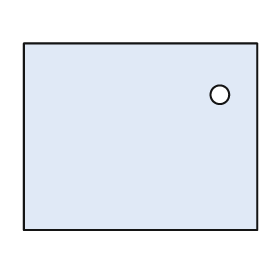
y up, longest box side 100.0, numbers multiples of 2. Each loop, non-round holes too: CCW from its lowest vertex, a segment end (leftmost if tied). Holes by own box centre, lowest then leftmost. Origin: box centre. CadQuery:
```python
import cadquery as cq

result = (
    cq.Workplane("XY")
    .moveTo(-50.0, -40.0)
    .lineTo(50.0, -40.0)
    .lineTo(50.0, 40.0)
    .lineTo(-50.0, 40.0)
    .close()
    .moveTo(34.0, 18.0)
    .circle(4.0)
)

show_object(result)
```